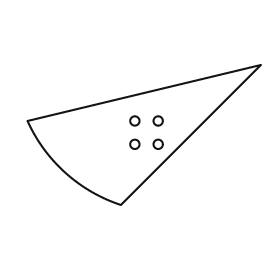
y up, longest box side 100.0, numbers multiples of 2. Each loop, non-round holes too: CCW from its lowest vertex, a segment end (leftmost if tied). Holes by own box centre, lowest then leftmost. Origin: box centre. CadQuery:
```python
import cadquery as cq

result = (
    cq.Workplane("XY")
    .moveTo(-10.0, -30.0)
    .lineTo(50.0, 30.0)
    .lineTo(-50.0, 6.0)
    .threePointArc((-34.0, -16.0), (-10.0, -30.0))
    .close()
    .moveTo(-4.0, -4.0)
    .circle(2.0)
    .moveTo(6.0, -4.0)
    .circle(2.0)
    .moveTo(-4.0, 6.0)
    .circle(2.0)
    .moveTo(6.0, 6.0)
    .circle(2.0)
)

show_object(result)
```